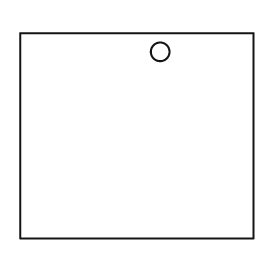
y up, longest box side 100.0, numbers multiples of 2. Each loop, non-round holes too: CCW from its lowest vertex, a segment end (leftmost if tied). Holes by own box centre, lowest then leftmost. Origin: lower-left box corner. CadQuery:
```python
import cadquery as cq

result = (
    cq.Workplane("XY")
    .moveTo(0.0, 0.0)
    .lineTo(100.0, 0.0)
    .lineTo(100.0, 88.0)
    .lineTo(0.0, 88.0)
    .close()
    .moveTo(60.0, 80.0)
    .circle(4.0)
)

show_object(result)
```